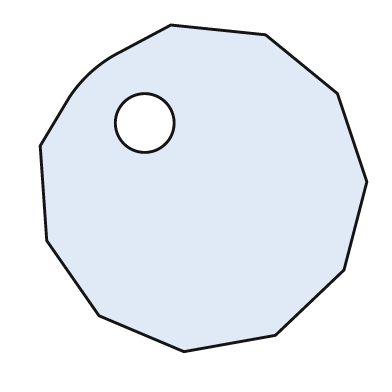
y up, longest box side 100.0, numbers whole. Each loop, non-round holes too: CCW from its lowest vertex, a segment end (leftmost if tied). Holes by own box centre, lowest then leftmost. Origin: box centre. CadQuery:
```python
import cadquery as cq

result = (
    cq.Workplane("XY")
    .moveTo(-6.0, -50.0)
    .lineTo(22.0, -45.0)
    .lineTo(43.0, -25.0)
    .lineTo(50.0, 2.0)
    .lineTo(41.0, 29.0)
    .lineTo(19.0, 47.0)
    .lineTo(-10.0, 50.0)
    .lineTo(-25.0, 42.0)
    .threePointArc((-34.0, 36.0), (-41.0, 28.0))
    .lineTo(-50.0, 13.0)
    .lineTo(-48.0, -16.0)
    .lineTo(-32.0, -39.0)
    .close()
    .moveTo(-18.0, 20.0)
    .circle(9.0)
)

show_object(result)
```